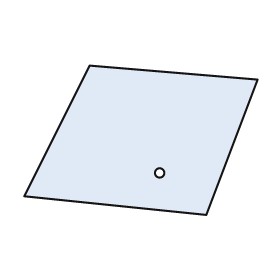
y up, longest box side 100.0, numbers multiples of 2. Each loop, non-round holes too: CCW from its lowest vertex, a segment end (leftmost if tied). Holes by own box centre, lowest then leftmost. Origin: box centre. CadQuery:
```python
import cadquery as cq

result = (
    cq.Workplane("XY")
    .moveTo(28.0, -32.0)
    .lineTo(50.0, 26.0)
    .lineTo(-22.0, 32.0)
    .lineTo(-50.0, -24.0)
    .close()
    .moveTo(8.0, -14.0)
    .circle(2.0)
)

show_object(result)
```